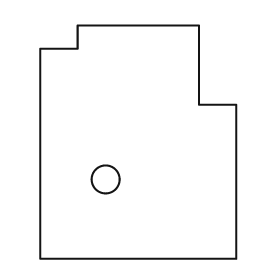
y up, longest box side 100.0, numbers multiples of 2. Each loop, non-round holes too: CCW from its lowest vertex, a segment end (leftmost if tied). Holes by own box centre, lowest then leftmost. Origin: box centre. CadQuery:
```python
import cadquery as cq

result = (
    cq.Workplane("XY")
    .moveTo(-42.0, -50.0)
    .lineTo(42.0, -50.0)
    .lineTo(42.0, 16.0)
    .lineTo(26.0, 16.0)
    .lineTo(26.0, 50.0)
    .lineTo(-26.0, 50.0)
    .lineTo(-26.0, 40.0)
    .lineTo(-42.0, 40.0)
    .close()
    .moveTo(-14.0, -16.0)
    .circle(6.0)
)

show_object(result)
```